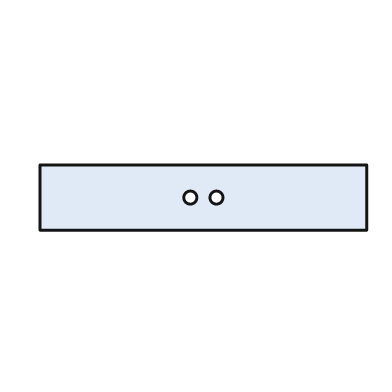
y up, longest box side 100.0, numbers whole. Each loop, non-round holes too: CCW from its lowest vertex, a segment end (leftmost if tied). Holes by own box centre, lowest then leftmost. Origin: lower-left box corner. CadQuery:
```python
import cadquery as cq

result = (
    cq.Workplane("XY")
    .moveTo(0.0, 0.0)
    .lineTo(100.0, 0.0)
    .lineTo(100.0, 20.0)
    .lineTo(0.0, 20.0)
    .close()
    .moveTo(46.0, 10.0)
    .circle(2.0)
    .moveTo(54.0, 10.0)
    .circle(2.0)
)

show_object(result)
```